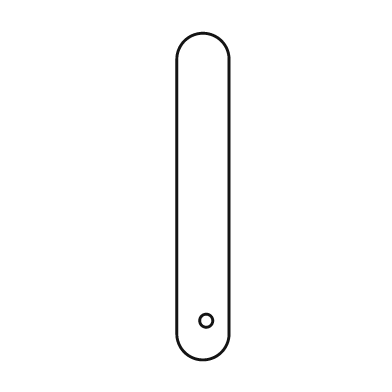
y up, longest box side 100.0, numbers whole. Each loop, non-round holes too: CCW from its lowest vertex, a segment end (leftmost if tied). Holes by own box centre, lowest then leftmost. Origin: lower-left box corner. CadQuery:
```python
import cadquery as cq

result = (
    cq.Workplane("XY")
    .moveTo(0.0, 8.0)
    .threePointArc((8.0, 0.0), (16.0, 8.0))
    .lineTo(16.0, 92.0)
    .threePointArc((8.0, 100.0), (0.0, 92.0))
    .close()
    .moveTo(9.0, 12.0)
    .circle(2.0)
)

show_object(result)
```